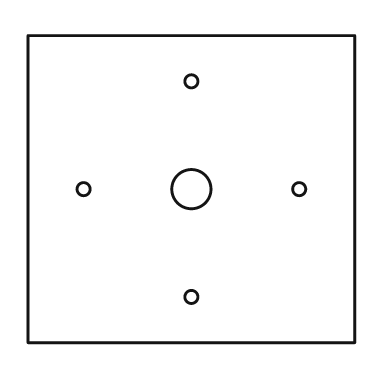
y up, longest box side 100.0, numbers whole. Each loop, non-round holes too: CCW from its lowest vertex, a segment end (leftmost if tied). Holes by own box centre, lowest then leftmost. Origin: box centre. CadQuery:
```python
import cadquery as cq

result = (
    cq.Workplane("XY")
    .moveTo(-50.0, -47.0)
    .lineTo(50.0, -47.0)
    .lineTo(50.0, 47.0)
    .lineTo(-50.0, 47.0)
    .close()
    .moveTo(0.0, -33.0)
    .circle(2.0)
    .moveTo(-33.0, 0.0)
    .circle(2.0)
    .moveTo(0.0, 0.0)
    .circle(6.0)
    .moveTo(33.0, 0.0)
    .circle(2.0)
    .moveTo(0.0, 33.0)
    .circle(2.0)
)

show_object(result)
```